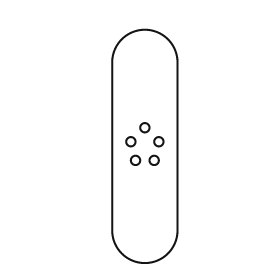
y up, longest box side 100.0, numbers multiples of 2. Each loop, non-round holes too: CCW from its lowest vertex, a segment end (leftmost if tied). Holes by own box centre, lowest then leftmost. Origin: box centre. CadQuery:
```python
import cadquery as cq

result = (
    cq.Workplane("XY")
    .moveTo(-14.0, -36.0)
    .threePointArc((0.0, -50.0), (14.0, -36.0))
    .lineTo(14.0, 36.0)
    .threePointArc((0.0, 50.0), (-14.0, 36.0))
    .close()
    .moveTo(-4.0, -6.0)
    .circle(2.0)
    .moveTo(4.0, -6.0)
    .circle(2.0)
    .moveTo(-6.0, 2.0)
    .circle(2.0)
    .moveTo(6.0, 2.0)
    .circle(2.0)
    .moveTo(0.0, 8.0)
    .circle(2.0)
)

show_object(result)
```